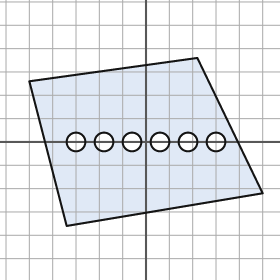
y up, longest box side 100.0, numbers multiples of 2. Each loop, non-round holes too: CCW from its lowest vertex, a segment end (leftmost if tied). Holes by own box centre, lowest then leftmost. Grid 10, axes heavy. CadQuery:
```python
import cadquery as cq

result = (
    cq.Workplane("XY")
    .moveTo(-34.0, -36.0)
    .lineTo(50.0, -22.0)
    .lineTo(22.0, 36.0)
    .lineTo(-50.0, 26.0)
    .close()
    .moveTo(-30.0, 0.0)
    .circle(4.0)
    .moveTo(-18.0, 0.0)
    .circle(4.0)
    .moveTo(-6.0, 0.0)
    .circle(4.0)
    .moveTo(6.0, 0.0)
    .circle(4.0)
    .moveTo(18.0, 0.0)
    .circle(4.0)
    .moveTo(30.0, 0.0)
    .circle(4.0)
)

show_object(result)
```